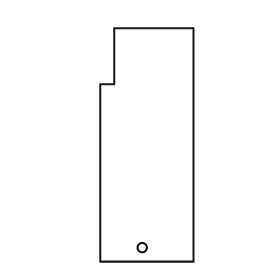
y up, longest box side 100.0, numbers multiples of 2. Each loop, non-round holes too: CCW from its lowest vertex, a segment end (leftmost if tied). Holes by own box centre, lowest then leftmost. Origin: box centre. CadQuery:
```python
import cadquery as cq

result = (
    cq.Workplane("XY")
    .moveTo(-20.0, -50.0)
    .lineTo(20.0, -50.0)
    .lineTo(20.0, 50.0)
    .lineTo(-14.0, 50.0)
    .lineTo(-14.0, 26.0)
    .lineTo(-20.0, 26.0)
    .close()
    .moveTo(-2.0, -44.0)
    .circle(2.0)
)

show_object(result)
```